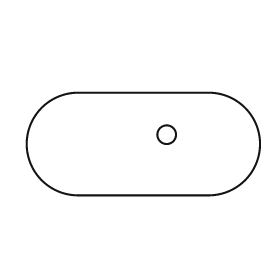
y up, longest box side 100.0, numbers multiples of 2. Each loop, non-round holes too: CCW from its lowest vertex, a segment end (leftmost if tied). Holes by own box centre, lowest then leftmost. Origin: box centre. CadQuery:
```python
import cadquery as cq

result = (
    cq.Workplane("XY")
    .moveTo(-28.0, -22.0)
    .lineTo(28.0, -22.0)
    .threePointArc((50.0, 0.0), (28.0, 22.0))
    .lineTo(-28.0, 22.0)
    .threePointArc((-50.0, 0.0), (-28.0, -22.0))
    .close()
    .moveTo(10.0, 4.0)
    .circle(4.0)
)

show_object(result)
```